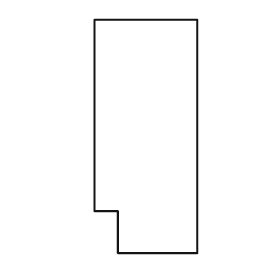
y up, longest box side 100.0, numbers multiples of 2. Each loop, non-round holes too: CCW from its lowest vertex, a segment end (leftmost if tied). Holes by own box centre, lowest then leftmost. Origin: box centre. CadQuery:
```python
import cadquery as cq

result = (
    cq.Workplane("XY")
    .moveTo(-12.0, -50.0)
    .lineTo(22.0, -50.0)
    .lineTo(22.0, 50.0)
    .lineTo(-22.0, 50.0)
    .lineTo(-22.0, -32.0)
    .lineTo(-12.0, -32.0)
    .close()
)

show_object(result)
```